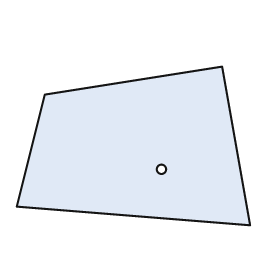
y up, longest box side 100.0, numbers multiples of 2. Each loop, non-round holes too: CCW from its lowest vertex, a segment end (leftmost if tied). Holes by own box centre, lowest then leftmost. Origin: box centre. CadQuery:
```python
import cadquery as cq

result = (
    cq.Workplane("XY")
    .moveTo(50.0, -34.0)
    .lineTo(38.0, 34.0)
    .lineTo(-38.0, 22.0)
    .lineTo(-50.0, -26.0)
    .close()
    .moveTo(12.0, -10.0)
    .circle(2.0)
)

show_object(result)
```